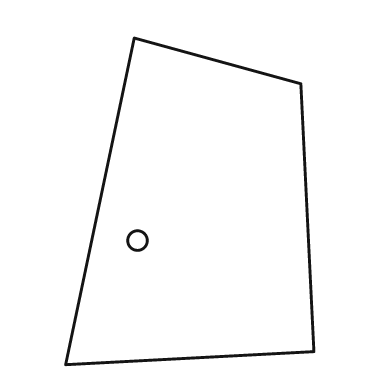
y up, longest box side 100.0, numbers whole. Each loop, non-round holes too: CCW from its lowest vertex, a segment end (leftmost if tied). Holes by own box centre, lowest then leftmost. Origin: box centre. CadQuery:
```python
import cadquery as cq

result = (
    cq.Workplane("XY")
    .moveTo(-38.0, -50.0)
    .lineTo(38.0, -46.0)
    .lineTo(34.0, 36.0)
    .lineTo(-17.0, 50.0)
    .close()
    .moveTo(-16.0, -12.0)
    .circle(3.0)
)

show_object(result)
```